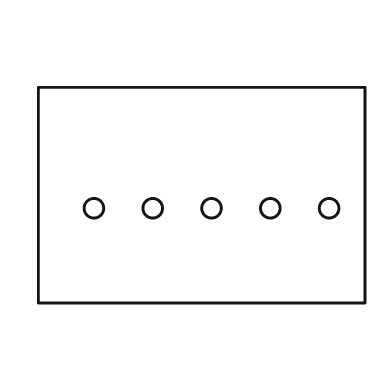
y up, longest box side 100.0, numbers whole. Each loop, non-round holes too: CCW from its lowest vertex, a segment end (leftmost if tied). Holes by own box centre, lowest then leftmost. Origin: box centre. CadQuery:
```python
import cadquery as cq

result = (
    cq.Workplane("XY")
    .moveTo(-50.0, -33.0)
    .lineTo(50.0, -33.0)
    .lineTo(50.0, 33.0)
    .lineTo(-50.0, 33.0)
    .close()
    .moveTo(-33.0, -4.0)
    .circle(3.0)
    .moveTo(-15.0, -4.0)
    .circle(3.0)
    .moveTo(3.0, -4.0)
    .circle(3.0)
    .moveTo(21.0, -4.0)
    .circle(3.0)
    .moveTo(39.0, -4.0)
    .circle(3.0)
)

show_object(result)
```